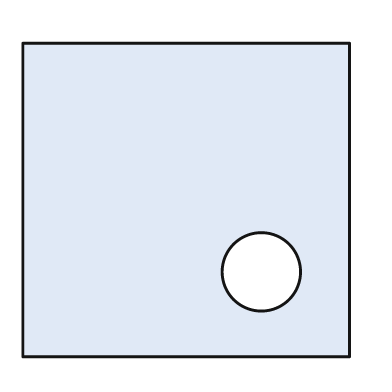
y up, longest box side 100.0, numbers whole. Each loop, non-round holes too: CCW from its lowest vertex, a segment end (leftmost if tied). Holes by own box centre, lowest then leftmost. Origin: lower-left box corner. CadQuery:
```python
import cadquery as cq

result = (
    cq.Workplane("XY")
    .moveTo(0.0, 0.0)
    .lineTo(100.0, 0.0)
    .lineTo(100.0, 96.0)
    .lineTo(0.0, 96.0)
    .close()
    .moveTo(73.0, 26.0)
    .circle(12.0)
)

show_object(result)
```